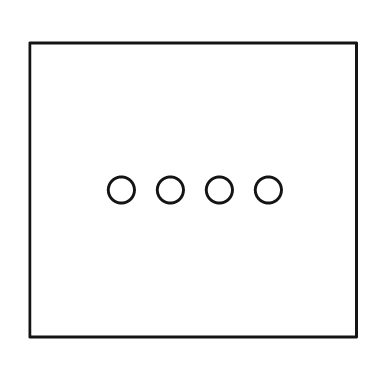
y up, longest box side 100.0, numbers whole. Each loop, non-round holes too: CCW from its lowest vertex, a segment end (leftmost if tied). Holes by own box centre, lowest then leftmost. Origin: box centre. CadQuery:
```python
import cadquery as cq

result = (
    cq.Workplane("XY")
    .moveTo(-50.0, -45.0)
    .lineTo(50.0, -45.0)
    .lineTo(50.0, 45.0)
    .lineTo(-50.0, 45.0)
    .close()
    .moveTo(-22.0, 0.0)
    .circle(4.0)
    .moveTo(-7.0, 0.0)
    .circle(4.0)
    .moveTo(8.0, 0.0)
    .circle(4.0)
    .moveTo(23.0, 0.0)
    .circle(4.0)
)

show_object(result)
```